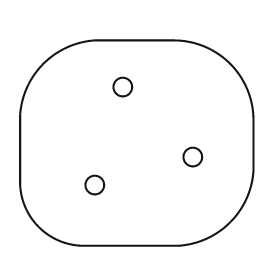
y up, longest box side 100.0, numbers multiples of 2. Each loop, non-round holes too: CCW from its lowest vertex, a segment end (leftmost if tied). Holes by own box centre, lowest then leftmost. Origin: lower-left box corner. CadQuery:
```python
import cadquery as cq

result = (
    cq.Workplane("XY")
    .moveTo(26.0, 0.0)
    .lineTo(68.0, 0.0)
    .threePointArc((90.0, 10.0), (100.0, 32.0))
    .lineTo(100.0, 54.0)
    .threePointArc((90.0, 78.0), (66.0, 88.0))
    .lineTo(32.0, 88.0)
    .threePointArc((10.0, 78.0), (0.0, 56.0))
    .lineTo(0.0, 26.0)
    .threePointArc((8.0, 8.0), (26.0, 0.0))
    .close()
    .moveTo(32.0, 26.0)
    .circle(4.0)
    .moveTo(74.0, 38.0)
    .circle(4.0)
    .moveTo(44.0, 68.0)
    .circle(4.0)
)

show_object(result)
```